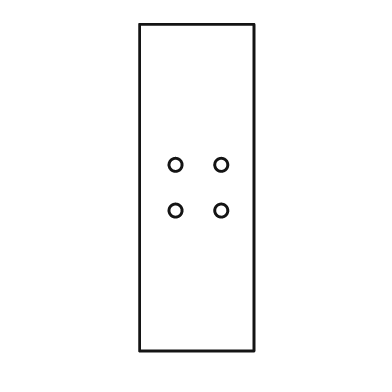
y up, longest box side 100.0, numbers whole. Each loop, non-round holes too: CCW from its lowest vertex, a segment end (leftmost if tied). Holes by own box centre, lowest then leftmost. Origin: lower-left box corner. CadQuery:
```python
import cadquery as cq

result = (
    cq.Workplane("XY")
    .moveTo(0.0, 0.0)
    .lineTo(35.0, 0.0)
    .lineTo(35.0, 100.0)
    .lineTo(0.0, 100.0)
    .close()
    .moveTo(11.0, 43.0)
    .circle(2.0)
    .moveTo(25.0, 43.0)
    .circle(2.0)
    .moveTo(11.0, 57.0)
    .circle(2.0)
    .moveTo(25.0, 57.0)
    .circle(2.0)
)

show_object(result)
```